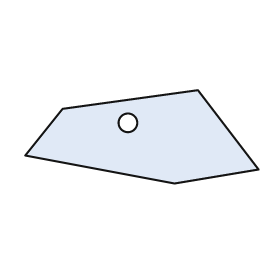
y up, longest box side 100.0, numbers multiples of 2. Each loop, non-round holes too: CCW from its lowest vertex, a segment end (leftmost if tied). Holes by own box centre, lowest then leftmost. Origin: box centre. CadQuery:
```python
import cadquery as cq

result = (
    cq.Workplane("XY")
    .moveTo(14.0, -20.0)
    .lineTo(50.0, -14.0)
    .lineTo(24.0, 20.0)
    .lineTo(-34.0, 12.0)
    .lineTo(-50.0, -8.0)
    .close()
    .moveTo(-6.0, 6.0)
    .circle(4.0)
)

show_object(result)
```